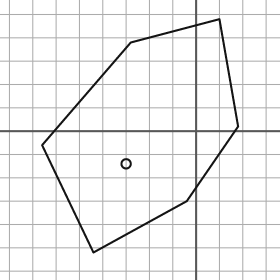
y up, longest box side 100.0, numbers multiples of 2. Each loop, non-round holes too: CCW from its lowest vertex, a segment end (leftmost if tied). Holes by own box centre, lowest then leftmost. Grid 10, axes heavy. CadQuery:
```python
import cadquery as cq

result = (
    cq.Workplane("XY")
    .moveTo(-44.0, -52.0)
    .lineTo(-4.0, -30.0)
    .lineTo(18.0, 2.0)
    .lineTo(10.0, 48.0)
    .lineTo(-28.0, 38.0)
    .lineTo(-66.0, -6.0)
    .close()
    .moveTo(-30.0, -14.0)
    .circle(2.0)
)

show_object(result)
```